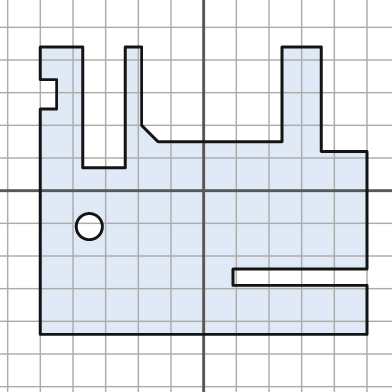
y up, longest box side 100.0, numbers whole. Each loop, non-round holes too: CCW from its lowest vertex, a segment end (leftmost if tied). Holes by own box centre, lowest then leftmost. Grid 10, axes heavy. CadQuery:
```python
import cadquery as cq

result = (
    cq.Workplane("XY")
    .moveTo(-50.0, -44.0)
    .lineTo(50.0, -44.0)
    .lineTo(50.0, -29.0)
    .lineTo(9.0, -29.0)
    .lineTo(9.0, -24.0)
    .lineTo(50.0, -24.0)
    .lineTo(50.0, 12.0)
    .lineTo(36.0, 12.0)
    .lineTo(36.0, 44.0)
    .lineTo(24.0, 44.0)
    .lineTo(24.0, 15.0)
    .lineTo(-14.0, 15.0)
    .lineTo(-19.0, 20.0)
    .lineTo(-19.0, 44.0)
    .lineTo(-24.0, 44.0)
    .lineTo(-24.0, 7.0)
    .lineTo(-37.0, 7.0)
    .lineTo(-37.0, 44.0)
    .lineTo(-50.0, 44.0)
    .lineTo(-50.0, 34.0)
    .lineTo(-45.0, 34.0)
    .lineTo(-45.0, 25.0)
    .lineTo(-50.0, 25.0)
    .close()
    .moveTo(-35.0, -11.0)
    .circle(4.0)
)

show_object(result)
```